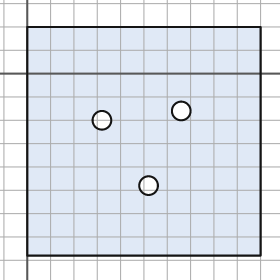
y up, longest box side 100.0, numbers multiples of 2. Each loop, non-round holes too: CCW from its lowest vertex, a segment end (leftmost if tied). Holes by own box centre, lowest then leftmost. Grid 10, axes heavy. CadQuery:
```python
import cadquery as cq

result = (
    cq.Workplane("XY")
    .moveTo(0.0, -78.0)
    .lineTo(100.0, -78.0)
    .lineTo(100.0, 20.0)
    .lineTo(0.0, 20.0)
    .close()
    .moveTo(52.0, -48.0)
    .circle(4.0)
    .moveTo(32.0, -20.0)
    .circle(4.0)
    .moveTo(66.0, -16.0)
    .circle(4.0)
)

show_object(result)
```